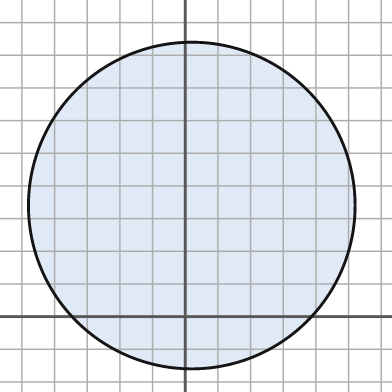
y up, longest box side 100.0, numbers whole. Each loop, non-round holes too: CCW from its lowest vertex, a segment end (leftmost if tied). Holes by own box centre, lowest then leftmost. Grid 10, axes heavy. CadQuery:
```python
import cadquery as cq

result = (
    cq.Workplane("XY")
    .moveTo(2.0, 34.0)
    .circle(50.0)
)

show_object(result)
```